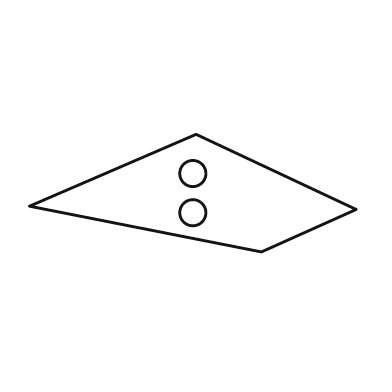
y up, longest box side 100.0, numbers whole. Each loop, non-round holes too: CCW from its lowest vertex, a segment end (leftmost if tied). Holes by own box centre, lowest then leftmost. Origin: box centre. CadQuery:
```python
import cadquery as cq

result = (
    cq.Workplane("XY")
    .moveTo(21.0, -18.0)
    .lineTo(50.0, -5.0)
    .lineTo(1.0, 18.0)
    .lineTo(-50.0, -4.0)
    .close()
    .moveTo(0.0, -6.0)
    .circle(4.0)
    .moveTo(0.0, 6.0)
    .circle(4.0)
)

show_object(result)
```